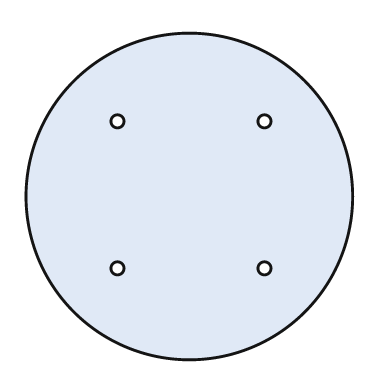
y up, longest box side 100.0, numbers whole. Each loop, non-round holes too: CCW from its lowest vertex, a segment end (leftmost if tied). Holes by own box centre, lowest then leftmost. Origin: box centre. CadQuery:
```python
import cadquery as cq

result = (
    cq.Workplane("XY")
    .moveTo(0.0, 0.0)
    .circle(50.0)
    .moveTo(-22.0, -22.0)
    .circle(2.0)
    .moveTo(23.0, -22.0)
    .circle(2.0)
    .moveTo(-22.0, 23.0)
    .circle(2.0)
    .moveTo(23.0, 23.0)
    .circle(2.0)
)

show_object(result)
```